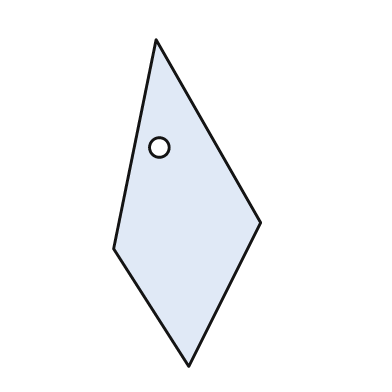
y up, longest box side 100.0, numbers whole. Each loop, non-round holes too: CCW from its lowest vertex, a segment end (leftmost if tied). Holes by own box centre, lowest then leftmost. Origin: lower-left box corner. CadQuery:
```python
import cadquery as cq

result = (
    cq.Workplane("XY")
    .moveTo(23.0, 0.0)
    .lineTo(45.0, 44.0)
    .lineTo(13.0, 100.0)
    .lineTo(0.0, 36.0)
    .close()
    .moveTo(14.0, 67.0)
    .circle(3.0)
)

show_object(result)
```